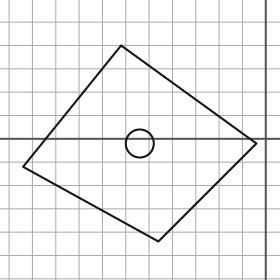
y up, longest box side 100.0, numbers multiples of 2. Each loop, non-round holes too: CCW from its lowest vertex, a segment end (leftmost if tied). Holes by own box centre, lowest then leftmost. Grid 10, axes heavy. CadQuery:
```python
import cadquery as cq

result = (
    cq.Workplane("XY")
    .moveTo(-46.0, -44.0)
    .lineTo(-4.0, -2.0)
    .lineTo(-62.0, 40.0)
    .lineTo(-104.0, -12.0)
    .close()
    .moveTo(-54.0, -2.0)
    .circle(6.0)
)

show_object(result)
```